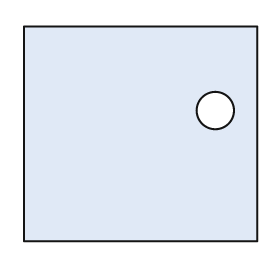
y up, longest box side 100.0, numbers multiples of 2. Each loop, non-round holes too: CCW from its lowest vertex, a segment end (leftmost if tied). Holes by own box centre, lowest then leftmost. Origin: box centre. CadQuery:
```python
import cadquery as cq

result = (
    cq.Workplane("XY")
    .moveTo(-50.0, -46.0)
    .lineTo(50.0, -46.0)
    .lineTo(50.0, 46.0)
    .lineTo(-50.0, 46.0)
    .close()
    .moveTo(32.0, 10.0)
    .circle(8.0)
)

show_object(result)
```